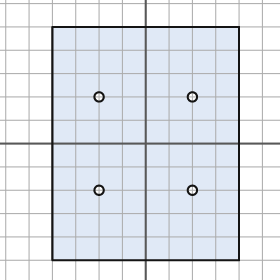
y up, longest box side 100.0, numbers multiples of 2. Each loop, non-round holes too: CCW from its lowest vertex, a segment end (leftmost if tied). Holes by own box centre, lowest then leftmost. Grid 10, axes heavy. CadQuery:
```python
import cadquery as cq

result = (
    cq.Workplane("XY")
    .moveTo(-40.0, -50.0)
    .lineTo(40.0, -50.0)
    .lineTo(40.0, 50.0)
    .lineTo(-40.0, 50.0)
    .close()
    .moveTo(-20.0, -20.0)
    .circle(2.0)
    .moveTo(20.0, -20.0)
    .circle(2.0)
    .moveTo(-20.0, 20.0)
    .circle(2.0)
    .moveTo(20.0, 20.0)
    .circle(2.0)
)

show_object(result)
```